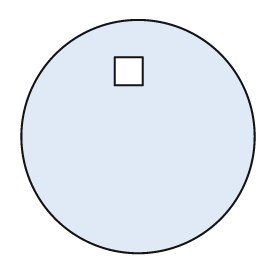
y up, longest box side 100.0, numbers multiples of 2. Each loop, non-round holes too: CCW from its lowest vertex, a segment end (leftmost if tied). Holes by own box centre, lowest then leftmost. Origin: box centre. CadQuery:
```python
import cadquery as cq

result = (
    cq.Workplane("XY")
    .moveTo(0.0, 0.0)
    .circle(50.0)
    .moveTo(-10.0, 22.0)
    .lineTo(2.0, 22.0)
    .lineTo(2.0, 34.0)
    .lineTo(-10.0, 34.0)
    .close()
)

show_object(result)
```